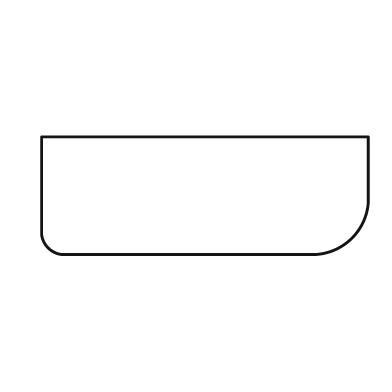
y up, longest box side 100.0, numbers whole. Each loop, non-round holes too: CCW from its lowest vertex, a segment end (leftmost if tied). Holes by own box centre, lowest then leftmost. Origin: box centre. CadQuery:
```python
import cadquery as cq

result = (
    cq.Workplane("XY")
    .moveTo(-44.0, -18.0)
    .lineTo(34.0, -18.0)
    .threePointArc((45.0, -13.0), (50.0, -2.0))
    .lineTo(50.0, 18.0)
    .lineTo(-50.0, 18.0)
    .lineTo(-50.0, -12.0)
    .threePointArc((-48.0, -16.0), (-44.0, -18.0))
    .close()
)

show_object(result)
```